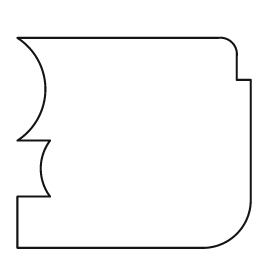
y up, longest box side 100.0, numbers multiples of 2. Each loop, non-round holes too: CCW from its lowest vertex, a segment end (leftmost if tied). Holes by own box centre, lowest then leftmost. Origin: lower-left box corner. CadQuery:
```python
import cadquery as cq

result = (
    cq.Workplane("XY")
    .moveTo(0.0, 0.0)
    .lineTo(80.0, 0.0)
    .threePointArc((94.0, 6.0), (100.0, 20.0))
    .lineTo(100.0, 72.0)
    .lineTo(94.0, 72.0)
    .lineTo(94.0, 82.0)
    .threePointArc((92.0, 88.0), (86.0, 90.0))
    .lineTo(0.0, 90.0)
    .threePointArc((12.0, 68.0), (0.0, 46.0))
    .lineTo(14.0, 46.0)
    .threePointArc((10.0, 34.0), (14.0, 22.0))
    .lineTo(0.0, 22.0)
    .close()
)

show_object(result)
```